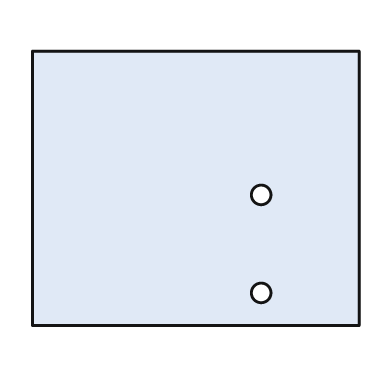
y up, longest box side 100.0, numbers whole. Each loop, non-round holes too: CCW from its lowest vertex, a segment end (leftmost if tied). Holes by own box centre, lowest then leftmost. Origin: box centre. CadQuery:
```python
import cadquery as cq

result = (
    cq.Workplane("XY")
    .moveTo(-50.0, -42.0)
    .lineTo(50.0, -42.0)
    .lineTo(50.0, 42.0)
    .lineTo(-50.0, 42.0)
    .close()
    .moveTo(20.0, -32.0)
    .circle(3.0)
    .moveTo(20.0, -2.0)
    .circle(3.0)
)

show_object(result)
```